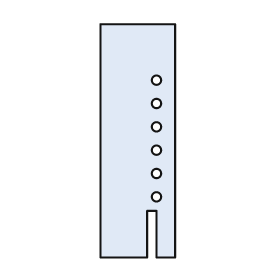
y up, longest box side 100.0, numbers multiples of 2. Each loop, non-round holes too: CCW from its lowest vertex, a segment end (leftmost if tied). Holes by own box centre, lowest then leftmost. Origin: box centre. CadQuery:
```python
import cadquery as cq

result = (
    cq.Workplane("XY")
    .moveTo(-16.0, -50.0)
    .lineTo(4.0, -50.0)
    .lineTo(4.0, -30.0)
    .lineTo(8.0, -30.0)
    .lineTo(8.0, -50.0)
    .lineTo(16.0, -50.0)
    .lineTo(16.0, 50.0)
    .lineTo(-16.0, 50.0)
    .close()
    .moveTo(8.0, -24.0)
    .circle(2.0)
    .moveTo(8.0, -14.0)
    .circle(2.0)
    .moveTo(8.0, -4.0)
    .circle(2.0)
    .moveTo(8.0, 6.0)
    .circle(2.0)
    .moveTo(8.0, 16.0)
    .circle(2.0)
    .moveTo(8.0, 26.0)
    .circle(2.0)
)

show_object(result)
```